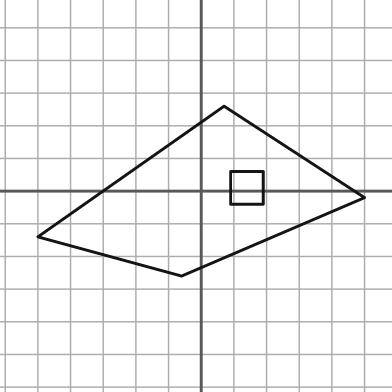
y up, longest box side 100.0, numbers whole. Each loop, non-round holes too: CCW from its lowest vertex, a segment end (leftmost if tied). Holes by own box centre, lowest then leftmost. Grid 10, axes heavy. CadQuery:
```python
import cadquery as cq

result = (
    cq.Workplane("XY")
    .moveTo(-6.0, -26.0)
    .lineTo(50.0, -2.0)
    .lineTo(7.0, 26.0)
    .lineTo(-50.0, -14.0)
    .close()
    .moveTo(9.0, -4.0)
    .lineTo(19.0, -4.0)
    .lineTo(19.0, 6.0)
    .lineTo(9.0, 6.0)
    .close()
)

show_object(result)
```